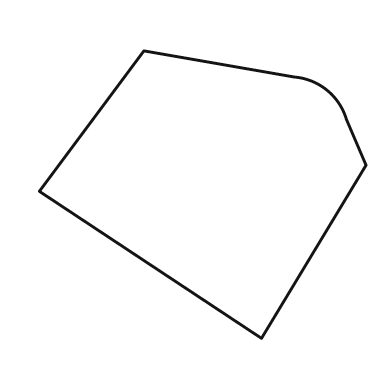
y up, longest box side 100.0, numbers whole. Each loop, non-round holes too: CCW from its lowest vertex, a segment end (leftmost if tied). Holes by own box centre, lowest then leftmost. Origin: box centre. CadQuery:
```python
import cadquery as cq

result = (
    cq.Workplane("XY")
    .moveTo(18.0, -44.0)
    .lineTo(50.0, 9.0)
    .lineTo(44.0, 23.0)
    .threePointArc((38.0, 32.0), (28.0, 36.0))
    .lineTo(-18.0, 44.0)
    .lineTo(-50.0, 1.0)
    .close()
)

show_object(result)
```